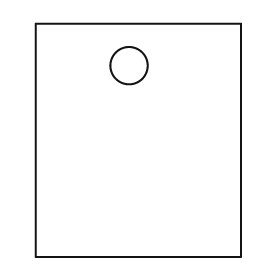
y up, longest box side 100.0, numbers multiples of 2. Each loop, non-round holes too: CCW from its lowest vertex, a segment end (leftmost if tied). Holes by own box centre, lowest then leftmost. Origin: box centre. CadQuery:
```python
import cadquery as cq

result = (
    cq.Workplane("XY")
    .moveTo(-44.0, -50.0)
    .lineTo(44.0, -50.0)
    .lineTo(44.0, 50.0)
    .lineTo(-44.0, 50.0)
    .close()
    .moveTo(-4.0, 32.0)
    .circle(8.0)
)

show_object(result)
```